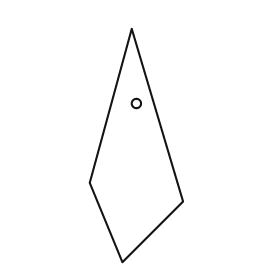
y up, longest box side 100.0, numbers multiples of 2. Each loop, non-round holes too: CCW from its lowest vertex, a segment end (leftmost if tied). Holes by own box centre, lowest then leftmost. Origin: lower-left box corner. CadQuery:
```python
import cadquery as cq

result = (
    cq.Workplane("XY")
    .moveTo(14.0, 0.0)
    .lineTo(40.0, 26.0)
    .lineTo(18.0, 100.0)
    .lineTo(0.0, 34.0)
    .close()
    .moveTo(20.0, 68.0)
    .circle(2.0)
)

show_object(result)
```